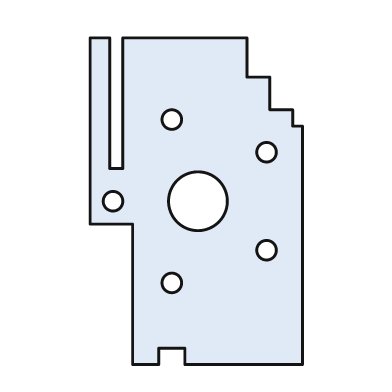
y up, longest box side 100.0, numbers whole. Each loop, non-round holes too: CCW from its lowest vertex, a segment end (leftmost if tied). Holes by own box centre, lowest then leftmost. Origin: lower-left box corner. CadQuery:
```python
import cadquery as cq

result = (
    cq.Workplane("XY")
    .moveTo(13.0, 0.0)
    .lineTo(21.0, 0.0)
    .lineTo(21.0, 5.0)
    .lineTo(29.0, 5.0)
    .lineTo(29.0, 0.0)
    .lineTo(65.0, 0.0)
    .lineTo(65.0, 73.0)
    .lineTo(62.0, 73.0)
    .lineTo(62.0, 78.0)
    .lineTo(55.0, 78.0)
    .lineTo(55.0, 88.0)
    .lineTo(48.0, 88.0)
    .lineTo(48.0, 100.0)
    .lineTo(10.0, 100.0)
    .lineTo(10.0, 60.0)
    .lineTo(6.0, 60.0)
    .lineTo(6.0, 100.0)
    .lineTo(0.0, 100.0)
    .lineTo(0.0, 43.0)
    .lineTo(13.0, 43.0)
    .close()
    .moveTo(25.0, 25.0)
    .circle(3.0)
    .moveTo(54.0, 35.0)
    .circle(3.0)
    .moveTo(7.0, 50.0)
    .circle(3.0)
    .moveTo(33.0, 50.0)
    .circle(9.0)
    .moveTo(54.0, 65.0)
    .circle(3.0)
    .moveTo(25.0, 75.0)
    .circle(3.0)
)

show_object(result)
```